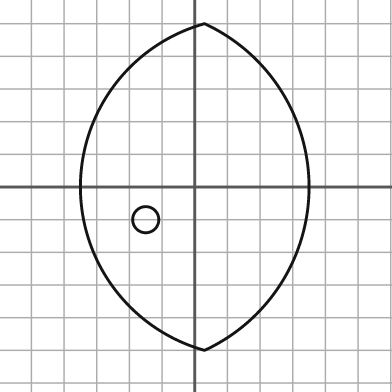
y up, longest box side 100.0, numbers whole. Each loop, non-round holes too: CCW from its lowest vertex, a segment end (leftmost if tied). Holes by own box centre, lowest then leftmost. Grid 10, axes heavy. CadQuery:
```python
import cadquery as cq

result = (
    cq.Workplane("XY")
    .moveTo(3.0, -50.0)
    .threePointArc((35.0, 0.0), (3.0, 50.0))
    .threePointArc((-35.0, 0.0), (3.0, -50.0))
    .close()
    .moveTo(-15.0, -10.0)
    .circle(4.0)
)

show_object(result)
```